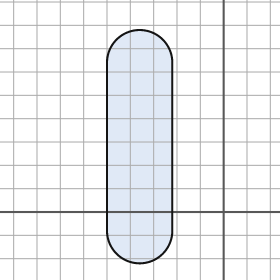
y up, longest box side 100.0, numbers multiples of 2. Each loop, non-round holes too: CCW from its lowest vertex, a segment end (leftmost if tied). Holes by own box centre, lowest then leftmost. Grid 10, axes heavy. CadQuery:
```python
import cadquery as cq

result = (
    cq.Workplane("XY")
    .moveTo(-50.0, -8.0)
    .threePointArc((-36.0, -22.0), (-22.0, -8.0))
    .lineTo(-22.0, 64.0)
    .threePointArc((-36.0, 78.0), (-50.0, 64.0))
    .close()
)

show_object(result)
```